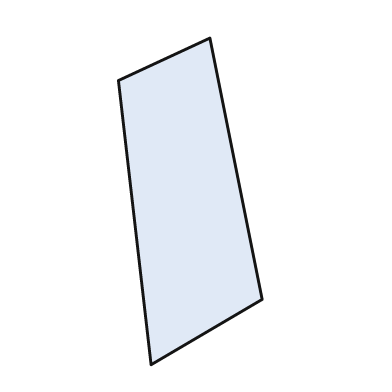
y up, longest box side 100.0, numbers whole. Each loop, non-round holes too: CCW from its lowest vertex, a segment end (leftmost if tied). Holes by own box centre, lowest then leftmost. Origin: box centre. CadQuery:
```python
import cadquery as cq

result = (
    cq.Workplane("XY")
    .moveTo(-12.0, -50.0)
    .lineTo(22.0, -30.0)
    .lineTo(6.0, 50.0)
    .lineTo(-22.0, 37.0)
    .close()
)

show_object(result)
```